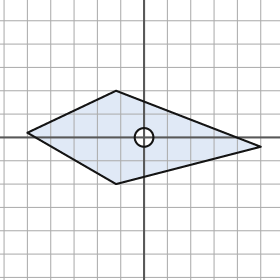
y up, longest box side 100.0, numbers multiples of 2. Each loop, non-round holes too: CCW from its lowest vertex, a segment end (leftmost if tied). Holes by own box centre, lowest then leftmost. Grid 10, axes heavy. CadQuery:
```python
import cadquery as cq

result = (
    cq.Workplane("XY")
    .moveTo(-12.0, -20.0)
    .lineTo(50.0, -4.0)
    .lineTo(-12.0, 20.0)
    .lineTo(-50.0, 2.0)
    .close()
    .moveTo(0.0, 0.0)
    .circle(4.0)
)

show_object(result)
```